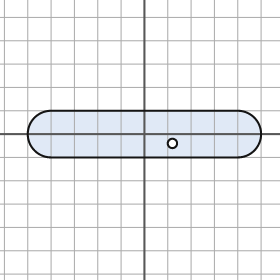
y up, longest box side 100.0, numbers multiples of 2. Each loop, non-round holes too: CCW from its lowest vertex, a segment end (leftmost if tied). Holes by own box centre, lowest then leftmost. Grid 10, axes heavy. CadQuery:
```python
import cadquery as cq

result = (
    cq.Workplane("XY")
    .moveTo(-40.0, -10.0)
    .lineTo(40.0, -10.0)
    .threePointArc((50.0, 0.0), (40.0, 10.0))
    .lineTo(-40.0, 10.0)
    .threePointArc((-50.0, 0.0), (-40.0, -10.0))
    .close()
    .moveTo(12.0, -4.0)
    .circle(2.0)
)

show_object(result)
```